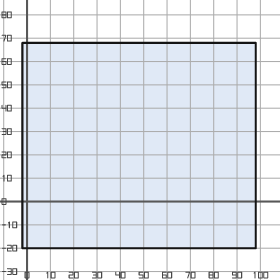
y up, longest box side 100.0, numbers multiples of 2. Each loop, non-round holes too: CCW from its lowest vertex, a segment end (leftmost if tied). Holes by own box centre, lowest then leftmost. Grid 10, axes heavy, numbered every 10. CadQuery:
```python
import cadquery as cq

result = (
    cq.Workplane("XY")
    .moveTo(-2.0, -20.0)
    .lineTo(98.0, -20.0)
    .lineTo(98.0, 68.0)
    .lineTo(-2.0, 68.0)
    .close()
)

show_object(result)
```